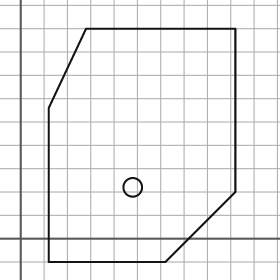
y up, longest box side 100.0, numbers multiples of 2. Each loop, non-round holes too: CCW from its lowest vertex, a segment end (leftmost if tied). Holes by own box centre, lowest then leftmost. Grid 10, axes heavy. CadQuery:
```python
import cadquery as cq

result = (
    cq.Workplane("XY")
    .moveTo(12.0, -10.0)
    .lineTo(62.0, -10.0)
    .lineTo(92.0, 20.0)
    .lineTo(92.0, 90.0)
    .lineTo(28.0, 90.0)
    .lineTo(12.0, 56.0)
    .close()
    .moveTo(48.0, 22.0)
    .circle(4.0)
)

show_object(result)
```